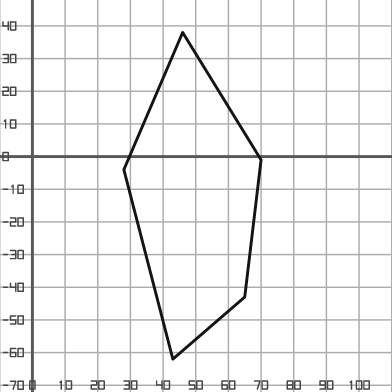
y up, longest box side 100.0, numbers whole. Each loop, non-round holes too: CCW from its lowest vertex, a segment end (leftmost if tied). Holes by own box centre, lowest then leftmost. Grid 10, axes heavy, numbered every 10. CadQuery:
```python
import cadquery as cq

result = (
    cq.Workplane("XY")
    .moveTo(43.0, -62.0)
    .lineTo(65.0, -43.0)
    .lineTo(70.0, -1.0)
    .lineTo(46.0, 38.0)
    .lineTo(28.0, -4.0)
    .close()
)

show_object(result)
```